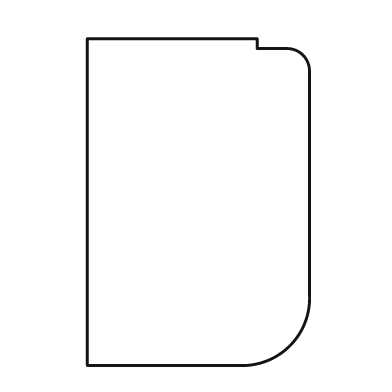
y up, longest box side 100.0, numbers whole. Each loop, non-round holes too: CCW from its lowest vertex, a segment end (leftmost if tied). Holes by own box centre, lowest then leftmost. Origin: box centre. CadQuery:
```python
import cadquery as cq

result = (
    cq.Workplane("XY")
    .moveTo(-34.0, -50.0)
    .lineTo(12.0, -50.0)
    .threePointArc((28.0, -44.0), (34.0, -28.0))
    .lineTo(34.0, 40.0)
    .threePointArc((32.0, 45.0), (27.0, 47.0))
    .lineTo(18.0, 47.0)
    .lineTo(18.0, 50.0)
    .lineTo(-34.0, 50.0)
    .close()
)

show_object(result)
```